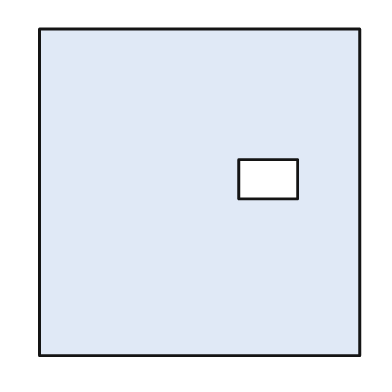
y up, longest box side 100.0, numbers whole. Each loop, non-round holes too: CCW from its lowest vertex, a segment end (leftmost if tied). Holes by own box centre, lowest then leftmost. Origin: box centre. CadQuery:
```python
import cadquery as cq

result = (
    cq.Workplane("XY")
    .moveTo(-49.0, -50.0)
    .lineTo(49.0, -50.0)
    .lineTo(49.0, 50.0)
    .lineTo(-49.0, 50.0)
    .close()
    .moveTo(12.0, -2.0)
    .lineTo(30.0, -2.0)
    .lineTo(30.0, 10.0)
    .lineTo(12.0, 10.0)
    .close()
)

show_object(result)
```